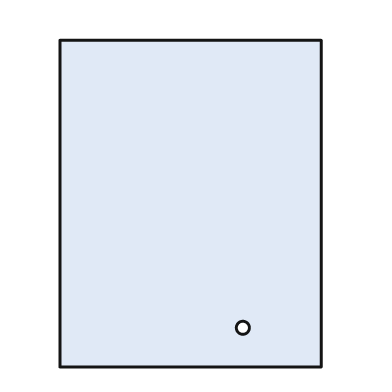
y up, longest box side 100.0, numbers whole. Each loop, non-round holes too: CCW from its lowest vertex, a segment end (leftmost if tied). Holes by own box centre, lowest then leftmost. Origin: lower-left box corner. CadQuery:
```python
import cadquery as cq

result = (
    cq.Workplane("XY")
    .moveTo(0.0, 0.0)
    .lineTo(80.0, 0.0)
    .lineTo(80.0, 100.0)
    .lineTo(0.0, 100.0)
    .close()
    .moveTo(56.0, 12.0)
    .circle(2.0)
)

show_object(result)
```